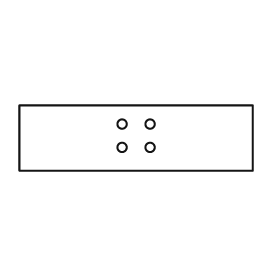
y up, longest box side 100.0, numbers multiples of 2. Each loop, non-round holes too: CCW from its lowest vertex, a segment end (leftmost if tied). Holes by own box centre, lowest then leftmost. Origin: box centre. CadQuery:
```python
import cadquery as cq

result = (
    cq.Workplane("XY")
    .moveTo(-50.0, -14.0)
    .lineTo(50.0, -14.0)
    .lineTo(50.0, 14.0)
    .lineTo(-50.0, 14.0)
    .close()
    .moveTo(-6.0, -4.0)
    .circle(2.0)
    .moveTo(6.0, -4.0)
    .circle(2.0)
    .moveTo(-6.0, 6.0)
    .circle(2.0)
    .moveTo(6.0, 6.0)
    .circle(2.0)
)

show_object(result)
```